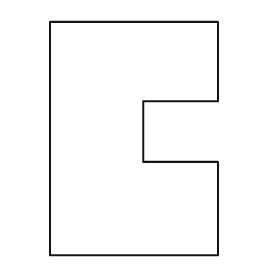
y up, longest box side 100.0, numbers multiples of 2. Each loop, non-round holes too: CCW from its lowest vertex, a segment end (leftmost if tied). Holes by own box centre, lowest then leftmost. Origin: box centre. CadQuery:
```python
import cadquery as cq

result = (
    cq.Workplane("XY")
    .moveTo(-36.0, -50.0)
    .lineTo(36.0, -50.0)
    .lineTo(36.0, -10.0)
    .lineTo(4.0, -10.0)
    .lineTo(4.0, 16.0)
    .lineTo(36.0, 16.0)
    .lineTo(36.0, 50.0)
    .lineTo(-36.0, 50.0)
    .close()
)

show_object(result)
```